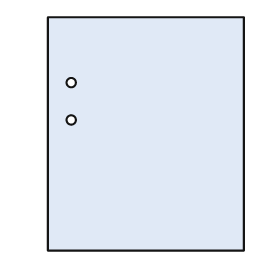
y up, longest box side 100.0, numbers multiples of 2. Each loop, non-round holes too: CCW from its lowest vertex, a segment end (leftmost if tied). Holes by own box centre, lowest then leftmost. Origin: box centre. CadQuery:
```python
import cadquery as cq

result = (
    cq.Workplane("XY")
    .moveTo(-42.0, -50.0)
    .lineTo(42.0, -50.0)
    .lineTo(42.0, 50.0)
    .lineTo(-42.0, 50.0)
    .close()
    .moveTo(-32.0, 6.0)
    .circle(2.0)
    .moveTo(-32.0, 22.0)
    .circle(2.0)
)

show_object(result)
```